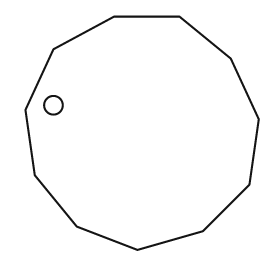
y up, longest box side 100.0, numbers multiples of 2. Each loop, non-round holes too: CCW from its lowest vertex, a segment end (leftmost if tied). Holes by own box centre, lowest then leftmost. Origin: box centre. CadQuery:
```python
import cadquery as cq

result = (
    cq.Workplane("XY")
    .moveTo(-2.0, -50.0)
    .lineTo(26.0, -42.0)
    .lineTo(46.0, -22.0)
    .lineTo(50.0, 6.0)
    .lineTo(38.0, 32.0)
    .lineTo(16.0, 50.0)
    .lineTo(-12.0, 50.0)
    .lineTo(-38.0, 36.0)
    .lineTo(-50.0, 10.0)
    .lineTo(-46.0, -18.0)
    .lineTo(-28.0, -40.0)
    .close()
    .moveTo(-38.0, 12.0)
    .circle(4.0)
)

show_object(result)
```